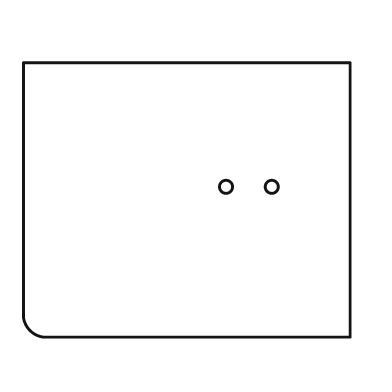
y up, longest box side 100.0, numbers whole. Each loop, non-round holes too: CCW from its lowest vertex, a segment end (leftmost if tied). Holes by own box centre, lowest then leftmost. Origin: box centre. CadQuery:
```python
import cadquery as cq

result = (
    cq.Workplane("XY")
    .moveTo(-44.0, -42.0)
    .lineTo(50.0, -42.0)
    .lineTo(50.0, 42.0)
    .lineTo(-50.0, 42.0)
    .lineTo(-50.0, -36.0)
    .threePointArc((-48.0, -40.0), (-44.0, -42.0))
    .close()
    .moveTo(12.0, 4.0)
    .circle(2.0)
    .moveTo(26.0, 4.0)
    .circle(2.0)
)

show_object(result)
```